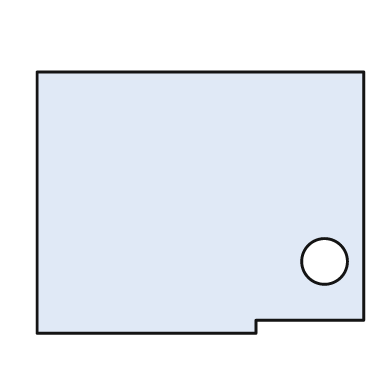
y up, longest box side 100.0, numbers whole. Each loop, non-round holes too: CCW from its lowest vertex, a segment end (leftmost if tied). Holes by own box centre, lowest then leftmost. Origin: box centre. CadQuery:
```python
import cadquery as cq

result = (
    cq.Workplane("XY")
    .moveTo(-50.0, -40.0)
    .lineTo(17.0, -40.0)
    .lineTo(17.0, -36.0)
    .lineTo(50.0, -36.0)
    .lineTo(50.0, 40.0)
    .lineTo(-50.0, 40.0)
    .close()
    .moveTo(38.0, -18.0)
    .circle(7.0)
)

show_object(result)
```